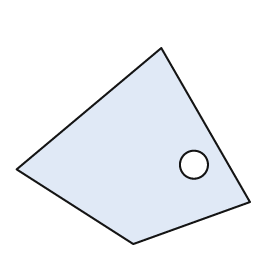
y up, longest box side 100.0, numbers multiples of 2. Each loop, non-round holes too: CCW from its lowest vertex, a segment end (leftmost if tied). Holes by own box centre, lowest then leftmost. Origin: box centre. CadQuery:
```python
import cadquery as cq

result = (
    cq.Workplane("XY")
    .moveTo(0.0, -42.0)
    .lineTo(50.0, -24.0)
    .lineTo(12.0, 42.0)
    .lineTo(-50.0, -10.0)
    .close()
    .moveTo(26.0, -8.0)
    .circle(6.0)
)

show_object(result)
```